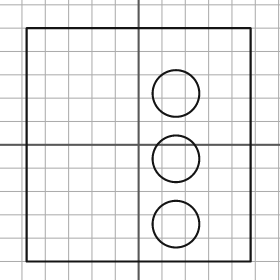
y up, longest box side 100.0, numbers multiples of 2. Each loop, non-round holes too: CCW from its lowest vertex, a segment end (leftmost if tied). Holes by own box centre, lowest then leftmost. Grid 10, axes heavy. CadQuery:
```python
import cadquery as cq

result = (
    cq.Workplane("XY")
    .moveTo(-48.0, -50.0)
    .lineTo(48.0, -50.0)
    .lineTo(48.0, 50.0)
    .lineTo(-48.0, 50.0)
    .close()
    .moveTo(16.0, -34.0)
    .circle(10.0)
    .moveTo(16.0, -6.0)
    .circle(10.0)
    .moveTo(16.0, 22.0)
    .circle(10.0)
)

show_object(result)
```